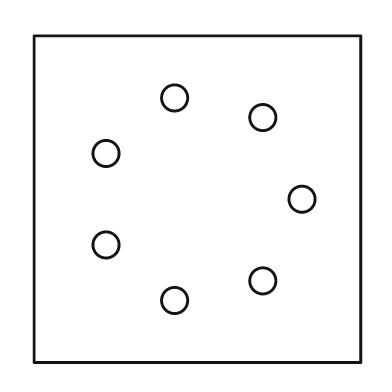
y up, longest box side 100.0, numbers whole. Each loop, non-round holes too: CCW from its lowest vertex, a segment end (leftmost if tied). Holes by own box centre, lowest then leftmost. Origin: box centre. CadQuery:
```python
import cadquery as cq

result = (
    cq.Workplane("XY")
    .moveTo(-50.0, -50.0)
    .lineTo(50.0, -50.0)
    .lineTo(50.0, 50.0)
    .lineTo(-50.0, 50.0)
    .close()
    .moveTo(-7.0, -31.0)
    .circle(4.0)
    .moveTo(20.0, -25.0)
    .circle(4.0)
    .moveTo(-28.0, -14.0)
    .circle(4.0)
    .moveTo(32.0, 0.0)
    .circle(4.0)
    .moveTo(-28.0, 14.0)
    .circle(4.0)
    .moveTo(20.0, 25.0)
    .circle(4.0)
    .moveTo(-7.0, 31.0)
    .circle(4.0)
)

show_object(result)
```